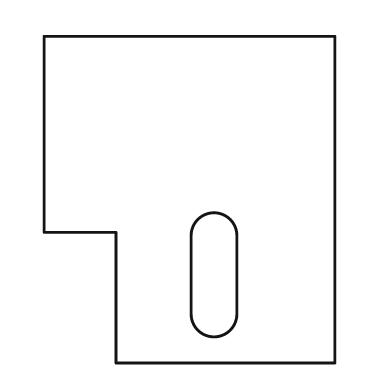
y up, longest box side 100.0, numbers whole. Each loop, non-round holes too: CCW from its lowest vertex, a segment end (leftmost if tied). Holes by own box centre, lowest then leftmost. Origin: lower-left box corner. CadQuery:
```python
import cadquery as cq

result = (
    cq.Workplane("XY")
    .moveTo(22.0, 0.0)
    .lineTo(89.0, 0.0)
    .lineTo(89.0, 100.0)
    .lineTo(0.0, 100.0)
    .lineTo(0.0, 40.0)
    .lineTo(22.0, 40.0)
    .close()
    .moveTo(45.0, 15.0)
    .threePointArc((52.0, 8.0), (59.0, 15.0))
    .lineTo(59.0, 39.0)
    .threePointArc((52.0, 46.0), (45.0, 39.0))
    .close()
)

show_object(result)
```